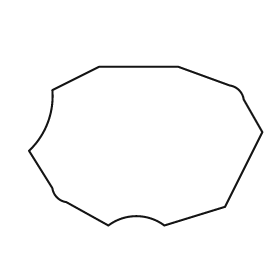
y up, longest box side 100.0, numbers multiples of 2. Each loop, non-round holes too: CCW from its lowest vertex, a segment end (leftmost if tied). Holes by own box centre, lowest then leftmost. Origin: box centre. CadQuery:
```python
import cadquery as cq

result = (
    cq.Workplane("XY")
    .moveTo(-16.0, -34.0)
    .threePointArc((-4.0, -30.0), (8.0, -34.0))
    .lineTo(34.0, -26.0)
    .lineTo(50.0, 6.0)
    .lineTo(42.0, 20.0)
    .threePointArc((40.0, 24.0), (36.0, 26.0))
    .lineTo(14.0, 34.0)
    .lineTo(-20.0, 34.0)
    .lineTo(-40.0, 24.0)
    .threePointArc((-42.0, 10.0), (-50.0, -2.0))
    .lineTo(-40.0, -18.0)
    .threePointArc((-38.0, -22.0), (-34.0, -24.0))
    .close()
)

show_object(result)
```